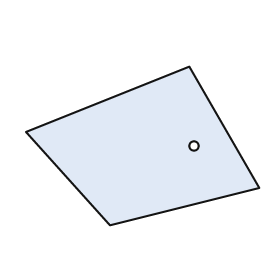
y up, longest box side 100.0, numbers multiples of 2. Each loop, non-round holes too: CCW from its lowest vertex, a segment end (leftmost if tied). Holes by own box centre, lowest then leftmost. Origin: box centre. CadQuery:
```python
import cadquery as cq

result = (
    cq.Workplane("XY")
    .moveTo(-14.0, -34.0)
    .lineTo(50.0, -18.0)
    .lineTo(20.0, 34.0)
    .lineTo(-50.0, 6.0)
    .close()
    .moveTo(22.0, 0.0)
    .circle(2.0)
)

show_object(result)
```